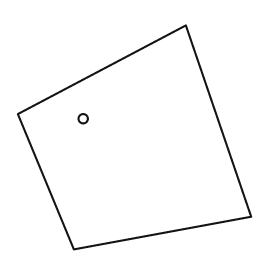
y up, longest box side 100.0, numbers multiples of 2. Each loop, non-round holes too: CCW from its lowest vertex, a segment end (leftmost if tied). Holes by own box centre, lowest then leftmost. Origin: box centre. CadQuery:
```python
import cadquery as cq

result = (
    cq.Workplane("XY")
    .moveTo(-26.0, -48.0)
    .lineTo(50.0, -34.0)
    .lineTo(22.0, 48.0)
    .lineTo(-50.0, 10.0)
    .close()
    .moveTo(-22.0, 8.0)
    .circle(2.0)
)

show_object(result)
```